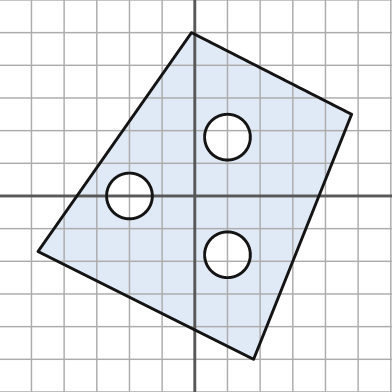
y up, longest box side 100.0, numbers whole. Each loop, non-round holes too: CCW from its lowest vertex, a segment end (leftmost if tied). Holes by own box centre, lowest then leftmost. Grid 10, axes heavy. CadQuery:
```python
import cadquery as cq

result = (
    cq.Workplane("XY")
    .moveTo(18.0, -50.0)
    .lineTo(48.0, 25.0)
    .lineTo(-1.0, 50.0)
    .lineTo(-48.0, -17.0)
    .close()
    .moveTo(10.0, -18.0)
    .circle(7.0)
    .moveTo(-20.0, 0.0)
    .circle(7.0)
    .moveTo(10.0, 18.0)
    .circle(7.0)
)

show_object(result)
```